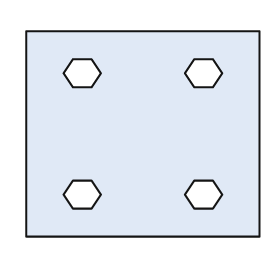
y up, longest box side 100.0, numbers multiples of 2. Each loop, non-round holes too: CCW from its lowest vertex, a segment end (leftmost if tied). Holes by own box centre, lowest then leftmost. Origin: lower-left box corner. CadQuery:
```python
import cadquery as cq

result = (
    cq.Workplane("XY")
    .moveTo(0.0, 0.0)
    .lineTo(100.0, 0.0)
    .lineTo(100.0, 88.0)
    .lineTo(0.0, 88.0)
    .close()
    .moveTo(20.0, 12.0)
    .lineTo(28.0, 12.0)
    .lineTo(32.0, 18.0)
    .lineTo(28.0, 24.0)
    .lineTo(20.0, 24.0)
    .lineTo(16.0, 18.0)
    .close()
    .moveTo(72.0, 12.0)
    .lineTo(80.0, 12.0)
    .lineTo(84.0, 18.0)
    .lineTo(80.0, 24.0)
    .lineTo(72.0, 24.0)
    .lineTo(68.0, 18.0)
    .close()
    .moveTo(20.0, 64.0)
    .lineTo(28.0, 64.0)
    .lineTo(32.0, 70.0)
    .lineTo(28.0, 76.0)
    .lineTo(20.0, 76.0)
    .lineTo(16.0, 70.0)
    .close()
    .moveTo(72.0, 64.0)
    .lineTo(80.0, 64.0)
    .lineTo(84.0, 70.0)
    .lineTo(80.0, 76.0)
    .lineTo(72.0, 76.0)
    .lineTo(68.0, 70.0)
    .close()
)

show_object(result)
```